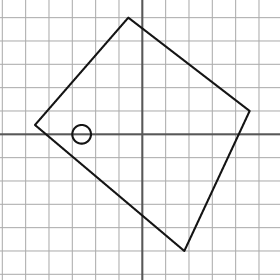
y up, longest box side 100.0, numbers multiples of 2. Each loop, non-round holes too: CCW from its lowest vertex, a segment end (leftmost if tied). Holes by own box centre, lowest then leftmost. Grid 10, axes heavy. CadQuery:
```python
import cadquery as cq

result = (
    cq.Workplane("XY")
    .moveTo(18.0, -50.0)
    .lineTo(46.0, 10.0)
    .lineTo(-6.0, 50.0)
    .lineTo(-46.0, 4.0)
    .close()
    .moveTo(-26.0, 0.0)
    .circle(4.0)
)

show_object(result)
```